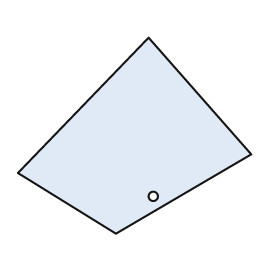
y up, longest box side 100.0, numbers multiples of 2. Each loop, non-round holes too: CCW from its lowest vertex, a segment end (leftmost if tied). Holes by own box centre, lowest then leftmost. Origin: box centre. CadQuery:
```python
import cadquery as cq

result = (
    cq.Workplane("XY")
    .moveTo(-8.0, -42.0)
    .lineTo(50.0, -8.0)
    .lineTo(6.0, 42.0)
    .lineTo(-50.0, -16.0)
    .close()
    .moveTo(8.0, -26.0)
    .circle(2.0)
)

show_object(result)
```